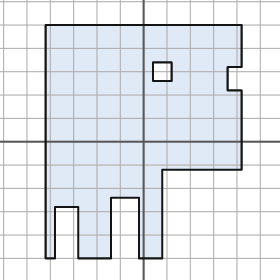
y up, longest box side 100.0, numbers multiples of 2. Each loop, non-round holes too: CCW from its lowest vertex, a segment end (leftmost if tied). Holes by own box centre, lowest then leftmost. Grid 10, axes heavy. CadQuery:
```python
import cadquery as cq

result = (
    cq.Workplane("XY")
    .moveTo(-42.0, -50.0)
    .lineTo(-38.0, -50.0)
    .lineTo(-38.0, -28.0)
    .lineTo(-28.0, -28.0)
    .lineTo(-28.0, -50.0)
    .lineTo(-14.0, -50.0)
    .lineTo(-14.0, -24.0)
    .lineTo(-2.0, -24.0)
    .lineTo(-2.0, -50.0)
    .lineTo(8.0, -50.0)
    .lineTo(8.0, -12.0)
    .lineTo(42.0, -12.0)
    .lineTo(42.0, 22.0)
    .lineTo(36.0, 22.0)
    .lineTo(36.0, 32.0)
    .lineTo(42.0, 32.0)
    .lineTo(42.0, 50.0)
    .lineTo(-42.0, 50.0)
    .close()
    .moveTo(4.0, 26.0)
    .lineTo(12.0, 26.0)
    .lineTo(12.0, 34.0)
    .lineTo(4.0, 34.0)
    .close()
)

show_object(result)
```